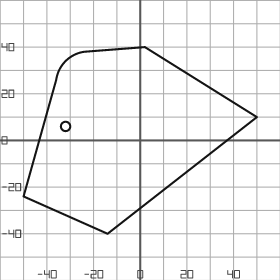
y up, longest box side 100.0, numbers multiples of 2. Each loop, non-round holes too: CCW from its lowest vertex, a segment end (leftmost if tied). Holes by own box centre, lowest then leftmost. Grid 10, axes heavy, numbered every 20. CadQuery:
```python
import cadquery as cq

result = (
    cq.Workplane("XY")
    .moveTo(-14.0, -40.0)
    .lineTo(50.0, 10.0)
    .lineTo(2.0, 40.0)
    .lineTo(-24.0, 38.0)
    .threePointArc((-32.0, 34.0), (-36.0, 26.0))
    .lineTo(-50.0, -24.0)
    .close()
    .moveTo(-32.0, 6.0)
    .circle(2.0)
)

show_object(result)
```